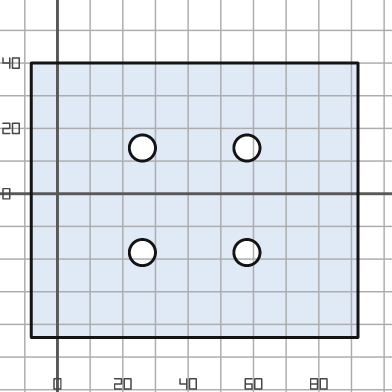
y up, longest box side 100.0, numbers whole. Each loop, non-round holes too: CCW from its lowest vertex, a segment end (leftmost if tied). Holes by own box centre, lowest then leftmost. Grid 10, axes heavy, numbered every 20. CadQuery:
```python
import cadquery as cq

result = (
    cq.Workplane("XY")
    .moveTo(-8.0, -44.0)
    .lineTo(92.0, -44.0)
    .lineTo(92.0, 40.0)
    .lineTo(-8.0, 40.0)
    .close()
    .moveTo(26.0, -18.0)
    .circle(4.0)
    .moveTo(58.0, -18.0)
    .circle(4.0)
    .moveTo(26.0, 14.0)
    .circle(4.0)
    .moveTo(58.0, 14.0)
    .circle(4.0)
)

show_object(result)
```